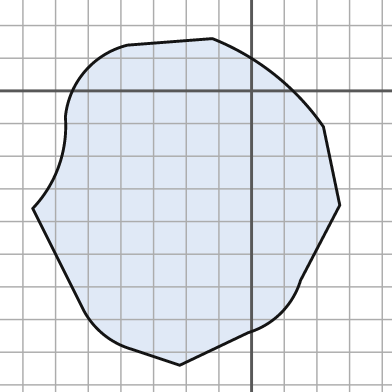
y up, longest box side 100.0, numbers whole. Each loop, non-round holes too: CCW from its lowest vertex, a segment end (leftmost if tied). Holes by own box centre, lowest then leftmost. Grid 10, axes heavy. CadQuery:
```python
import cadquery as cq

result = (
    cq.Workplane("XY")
    .moveTo(-22.0, -84.0)
    .lineTo(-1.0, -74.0)
    .threePointArc((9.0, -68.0), (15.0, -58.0))
    .lineTo(27.0, -35.0)
    .lineTo(22.0, -11.0)
    .threePointArc((7.0, 5.0), (-12.0, 16.0))
    .lineTo(-38.0, 14.0)
    .threePointArc((-51.0, 6.0), (-57.0, -8.0))
    .threePointArc((-59.0, -23.0), (-67.0, -36.0))
    .lineTo(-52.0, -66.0)
    .threePointArc((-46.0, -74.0), (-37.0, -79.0))
    .close()
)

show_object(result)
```